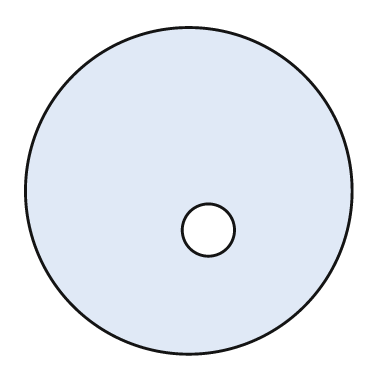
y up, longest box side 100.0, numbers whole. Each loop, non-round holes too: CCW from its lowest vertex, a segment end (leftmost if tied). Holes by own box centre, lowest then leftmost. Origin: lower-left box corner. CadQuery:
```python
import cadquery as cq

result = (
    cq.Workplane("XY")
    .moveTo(50.0, 50.0)
    .circle(50.0)
    .moveTo(56.0, 38.0)
    .circle(8.0)
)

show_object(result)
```